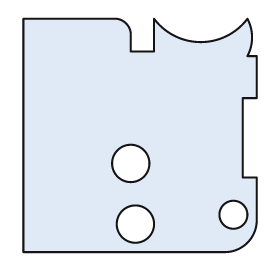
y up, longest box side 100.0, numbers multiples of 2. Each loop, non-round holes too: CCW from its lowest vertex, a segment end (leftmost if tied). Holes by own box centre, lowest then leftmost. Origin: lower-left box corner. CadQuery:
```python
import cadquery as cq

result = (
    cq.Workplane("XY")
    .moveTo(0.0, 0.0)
    .lineTo(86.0, 0.0)
    .threePointArc((96.0, 4.0), (100.0, 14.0))
    .lineTo(100.0, 32.0)
    .lineTo(94.0, 32.0)
    .lineTo(94.0, 66.0)
    .lineTo(100.0, 66.0)
    .lineTo(100.0, 84.0)
    .lineTo(96.0, 84.0)
    .threePointArc((98.0, 92.0), (96.0, 100.0))
    .threePointArc((76.0, 90.0), (56.0, 100.0))
    .lineTo(56.0, 86.0)
    .lineTo(46.0, 86.0)
    .lineTo(46.0, 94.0)
    .threePointArc((44.0, 98.0), (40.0, 100.0))
    .lineTo(0.0, 100.0)
    .close()
    .moveTo(48.0, 12.0)
    .circle(8.0)
    .moveTo(90.0, 16.0)
    .circle(6.0)
    .moveTo(46.0, 38.0)
    .circle(8.0)
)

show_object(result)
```